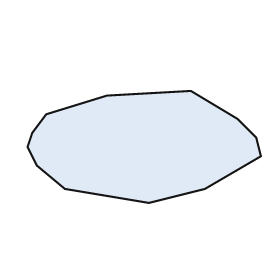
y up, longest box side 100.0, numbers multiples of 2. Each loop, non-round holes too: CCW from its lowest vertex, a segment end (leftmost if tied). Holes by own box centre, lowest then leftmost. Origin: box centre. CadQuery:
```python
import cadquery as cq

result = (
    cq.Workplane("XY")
    .moveTo(2.0, -24.0)
    .lineTo(26.0, -18.0)
    .lineTo(50.0, -4.0)
    .lineTo(48.0, 4.0)
    .lineTo(40.0, 12.0)
    .lineTo(20.0, 24.0)
    .lineTo(-16.0, 22.0)
    .lineTo(-42.0, 14.0)
    .lineTo(-48.0, 6.0)
    .lineTo(-50.0, 0.0)
    .lineTo(-46.0, -8.0)
    .lineTo(-34.0, -18.0)
    .close()
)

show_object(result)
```